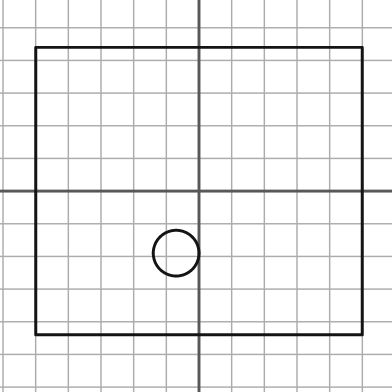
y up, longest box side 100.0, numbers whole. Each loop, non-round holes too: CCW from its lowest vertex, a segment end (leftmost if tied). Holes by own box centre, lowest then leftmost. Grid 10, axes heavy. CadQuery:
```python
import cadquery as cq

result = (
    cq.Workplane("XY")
    .moveTo(-50.0, -44.0)
    .lineTo(50.0, -44.0)
    .lineTo(50.0, 44.0)
    .lineTo(-50.0, 44.0)
    .close()
    .moveTo(-7.0, -19.0)
    .circle(7.0)
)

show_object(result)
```